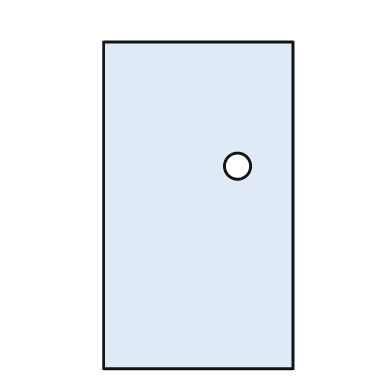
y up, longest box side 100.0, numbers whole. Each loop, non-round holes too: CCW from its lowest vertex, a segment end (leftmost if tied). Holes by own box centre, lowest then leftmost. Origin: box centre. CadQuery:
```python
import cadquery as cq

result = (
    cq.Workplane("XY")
    .moveTo(-29.0, -50.0)
    .lineTo(29.0, -50.0)
    .lineTo(29.0, 50.0)
    .lineTo(-29.0, 50.0)
    .close()
    .moveTo(12.0, 12.0)
    .circle(4.0)
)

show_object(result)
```